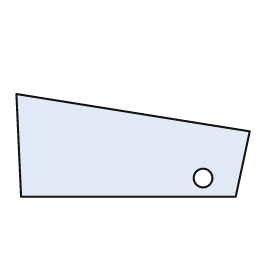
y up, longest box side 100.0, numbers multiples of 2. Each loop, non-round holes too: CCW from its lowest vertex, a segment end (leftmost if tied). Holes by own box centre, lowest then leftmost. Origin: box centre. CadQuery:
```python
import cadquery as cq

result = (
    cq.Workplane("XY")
    .moveTo(-48.0, -22.0)
    .lineTo(44.0, -22.0)
    .lineTo(50.0, 6.0)
    .lineTo(-50.0, 22.0)
    .close()
    .moveTo(30.0, -14.0)
    .circle(4.0)
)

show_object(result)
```